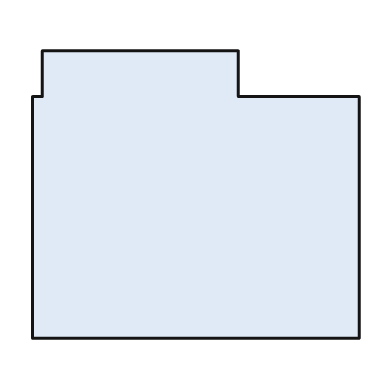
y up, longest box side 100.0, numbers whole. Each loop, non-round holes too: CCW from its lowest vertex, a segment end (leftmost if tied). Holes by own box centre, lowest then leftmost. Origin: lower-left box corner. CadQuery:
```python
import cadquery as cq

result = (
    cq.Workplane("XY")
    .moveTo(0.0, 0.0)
    .lineTo(100.0, 0.0)
    .lineTo(100.0, 74.0)
    .lineTo(63.0, 74.0)
    .lineTo(63.0, 88.0)
    .lineTo(3.0, 88.0)
    .lineTo(3.0, 74.0)
    .lineTo(0.0, 74.0)
    .close()
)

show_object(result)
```